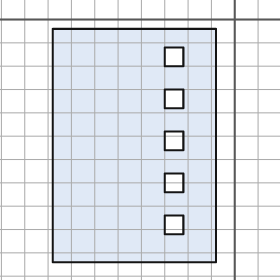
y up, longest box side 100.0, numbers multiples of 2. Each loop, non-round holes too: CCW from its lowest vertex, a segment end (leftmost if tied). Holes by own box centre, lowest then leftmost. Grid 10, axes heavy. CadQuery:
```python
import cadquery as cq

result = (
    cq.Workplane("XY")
    .moveTo(-78.0, -104.0)
    .lineTo(-8.0, -104.0)
    .lineTo(-8.0, -4.0)
    .lineTo(-78.0, -4.0)
    .close()
    .moveTo(-30.0, -92.0)
    .lineTo(-22.0, -92.0)
    .lineTo(-22.0, -84.0)
    .lineTo(-30.0, -84.0)
    .close()
    .moveTo(-30.0, -74.0)
    .lineTo(-22.0, -74.0)
    .lineTo(-22.0, -66.0)
    .lineTo(-30.0, -66.0)
    .close()
    .moveTo(-30.0, -56.0)
    .lineTo(-22.0, -56.0)
    .lineTo(-22.0, -48.0)
    .lineTo(-30.0, -48.0)
    .close()
    .moveTo(-30.0, -38.0)
    .lineTo(-22.0, -38.0)
    .lineTo(-22.0, -30.0)
    .lineTo(-30.0, -30.0)
    .close()
    .moveTo(-30.0, -20.0)
    .lineTo(-22.0, -20.0)
    .lineTo(-22.0, -12.0)
    .lineTo(-30.0, -12.0)
    .close()
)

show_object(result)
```